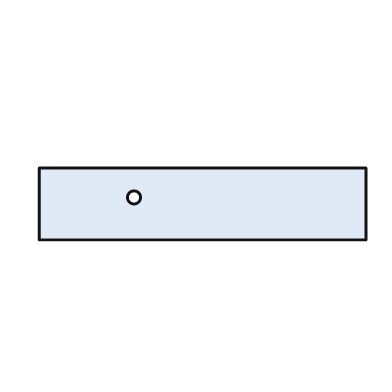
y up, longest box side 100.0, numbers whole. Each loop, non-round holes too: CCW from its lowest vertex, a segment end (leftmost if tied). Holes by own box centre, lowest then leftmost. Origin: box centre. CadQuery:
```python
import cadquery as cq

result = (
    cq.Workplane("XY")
    .moveTo(-50.0, -11.0)
    .lineTo(50.0, -11.0)
    .lineTo(50.0, 11.0)
    .lineTo(-50.0, 11.0)
    .close()
    .moveTo(-21.0, 2.0)
    .circle(2.0)
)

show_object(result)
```